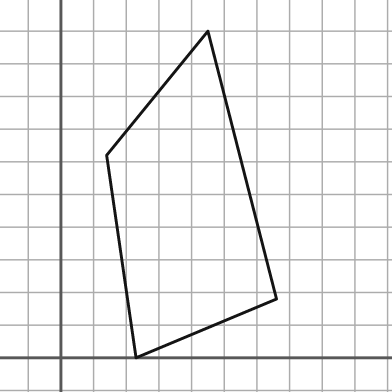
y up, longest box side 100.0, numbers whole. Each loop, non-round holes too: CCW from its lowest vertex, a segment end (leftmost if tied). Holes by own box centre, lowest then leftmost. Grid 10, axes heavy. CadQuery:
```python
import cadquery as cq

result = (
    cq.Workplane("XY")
    .moveTo(23.0, 0.0)
    .lineTo(66.0, 18.0)
    .lineTo(45.0, 100.0)
    .lineTo(14.0, 62.0)
    .close()
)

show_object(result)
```